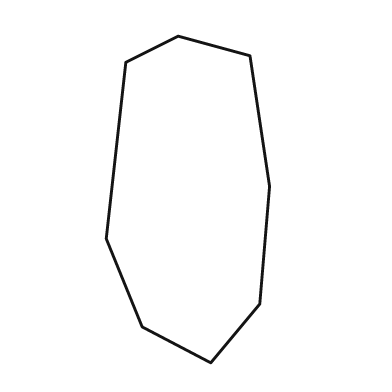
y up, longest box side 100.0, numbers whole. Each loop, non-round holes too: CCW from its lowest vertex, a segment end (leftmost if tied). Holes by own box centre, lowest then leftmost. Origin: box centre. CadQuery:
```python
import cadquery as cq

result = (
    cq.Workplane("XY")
    .moveTo(7.0, -50.0)
    .lineTo(22.0, -32.0)
    .lineTo(25.0, 4.0)
    .lineTo(19.0, 44.0)
    .lineTo(-3.0, 50.0)
    .lineTo(-19.0, 42.0)
    .lineTo(-25.0, -12.0)
    .lineTo(-14.0, -39.0)
    .close()
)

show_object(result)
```